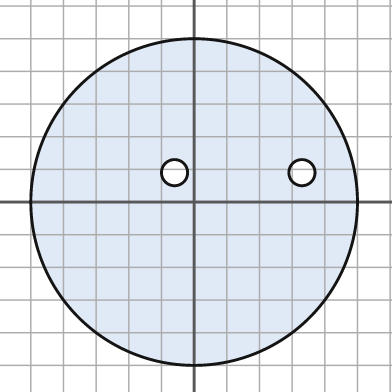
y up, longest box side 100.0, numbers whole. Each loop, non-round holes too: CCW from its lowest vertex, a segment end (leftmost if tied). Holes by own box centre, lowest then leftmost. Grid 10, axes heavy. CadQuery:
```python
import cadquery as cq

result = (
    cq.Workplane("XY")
    .moveTo(0.0, 0.0)
    .circle(50.0)
    .moveTo(-6.0, 9.0)
    .circle(4.0)
    .moveTo(33.0, 9.0)
    .circle(4.0)
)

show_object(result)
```